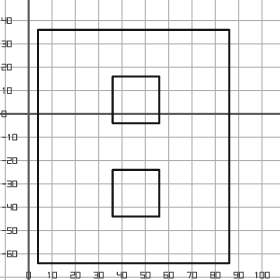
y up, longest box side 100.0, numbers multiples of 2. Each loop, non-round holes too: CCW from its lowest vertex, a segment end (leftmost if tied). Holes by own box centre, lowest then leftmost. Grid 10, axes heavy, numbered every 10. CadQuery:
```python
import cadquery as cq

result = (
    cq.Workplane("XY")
    .moveTo(4.0, -64.0)
    .lineTo(86.0, -64.0)
    .lineTo(86.0, 36.0)
    .lineTo(4.0, 36.0)
    .close()
    .moveTo(36.0, -44.0)
    .lineTo(56.0, -44.0)
    .lineTo(56.0, -24.0)
    .lineTo(36.0, -24.0)
    .close()
    .moveTo(36.0, -4.0)
    .lineTo(56.0, -4.0)
    .lineTo(56.0, 16.0)
    .lineTo(36.0, 16.0)
    .close()
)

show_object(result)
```